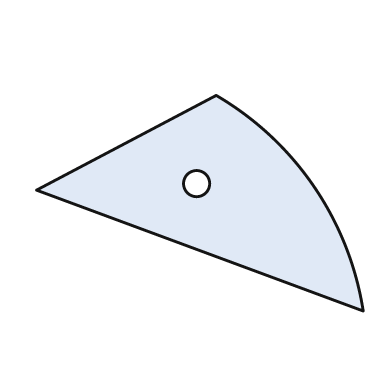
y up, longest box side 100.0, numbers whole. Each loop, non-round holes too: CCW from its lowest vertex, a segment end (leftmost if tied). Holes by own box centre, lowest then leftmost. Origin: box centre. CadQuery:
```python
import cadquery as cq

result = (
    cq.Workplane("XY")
    .moveTo(50.0, -33.0)
    .threePointArc((35.0, 5.0), (5.0, 33.0))
    .lineTo(-50.0, 4.0)
    .close()
    .moveTo(-1.0, 6.0)
    .circle(4.0)
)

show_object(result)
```